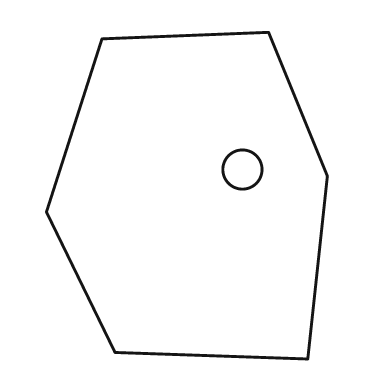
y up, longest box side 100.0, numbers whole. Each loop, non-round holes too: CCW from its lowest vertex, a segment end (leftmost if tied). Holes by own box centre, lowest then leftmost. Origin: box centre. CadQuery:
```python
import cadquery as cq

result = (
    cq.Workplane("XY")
    .moveTo(37.0, -50.0)
    .lineTo(43.0, 6.0)
    .lineTo(25.0, 50.0)
    .lineTo(-26.0, 48.0)
    .lineTo(-43.0, -5.0)
    .lineTo(-22.0, -48.0)
    .close()
    .moveTo(17.0, 8.0)
    .circle(6.0)
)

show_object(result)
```